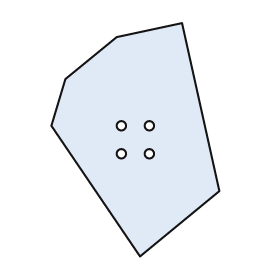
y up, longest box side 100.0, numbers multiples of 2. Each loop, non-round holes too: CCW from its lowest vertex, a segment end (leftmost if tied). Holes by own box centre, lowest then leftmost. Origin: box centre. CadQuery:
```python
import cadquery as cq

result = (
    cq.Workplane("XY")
    .moveTo(2.0, -50.0)
    .lineTo(36.0, -22.0)
    .lineTo(20.0, 50.0)
    .lineTo(-8.0, 44.0)
    .lineTo(-30.0, 26.0)
    .lineTo(-36.0, 6.0)
    .close()
    .moveTo(-6.0, -6.0)
    .circle(2.0)
    .moveTo(6.0, -6.0)
    .circle(2.0)
    .moveTo(-6.0, 6.0)
    .circle(2.0)
    .moveTo(6.0, 6.0)
    .circle(2.0)
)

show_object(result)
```